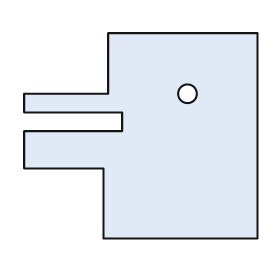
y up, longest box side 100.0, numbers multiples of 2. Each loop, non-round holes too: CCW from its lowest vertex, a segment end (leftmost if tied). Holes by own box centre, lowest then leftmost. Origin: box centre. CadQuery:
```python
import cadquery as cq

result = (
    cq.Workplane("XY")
    .moveTo(-16.0, -44.0)
    .lineTo(50.0, -44.0)
    .lineTo(50.0, 44.0)
    .lineTo(-14.0, 44.0)
    .lineTo(-14.0, 18.0)
    .lineTo(-50.0, 18.0)
    .lineTo(-50.0, 10.0)
    .lineTo(-8.0, 10.0)
    .lineTo(-8.0, 2.0)
    .lineTo(-50.0, 2.0)
    .lineTo(-50.0, -14.0)
    .lineTo(-16.0, -14.0)
    .close()
    .moveTo(20.0, 18.0)
    .circle(4.0)
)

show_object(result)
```